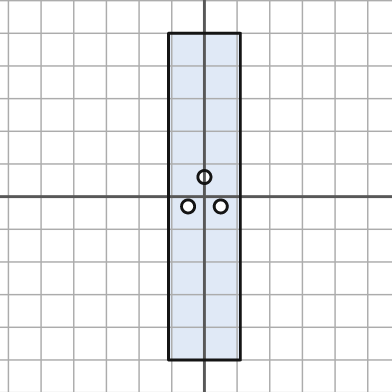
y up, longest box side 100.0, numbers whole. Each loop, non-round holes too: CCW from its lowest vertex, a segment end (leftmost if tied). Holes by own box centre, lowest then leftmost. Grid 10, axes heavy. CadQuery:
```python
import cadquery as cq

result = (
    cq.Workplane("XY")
    .moveTo(-11.0, -50.0)
    .lineTo(11.0, -50.0)
    .lineTo(11.0, 50.0)
    .lineTo(-11.0, 50.0)
    .close()
    .moveTo(-5.0, -3.0)
    .circle(2.0)
    .moveTo(5.0, -3.0)
    .circle(2.0)
    .moveTo(0.0, 6.0)
    .circle(2.0)
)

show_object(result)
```